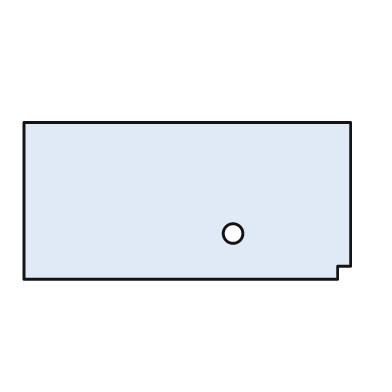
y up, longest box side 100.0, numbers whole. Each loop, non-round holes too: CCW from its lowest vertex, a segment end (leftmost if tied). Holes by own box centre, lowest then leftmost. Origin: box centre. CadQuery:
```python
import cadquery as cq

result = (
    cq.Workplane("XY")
    .moveTo(-50.0, -24.0)
    .lineTo(46.0, -24.0)
    .lineTo(46.0, -20.0)
    .lineTo(50.0, -20.0)
    .lineTo(50.0, 24.0)
    .lineTo(-50.0, 24.0)
    .close()
    .moveTo(14.0, -10.0)
    .circle(3.0)
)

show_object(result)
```